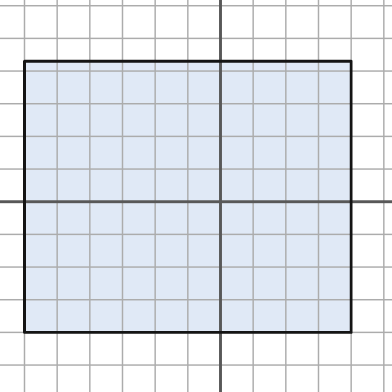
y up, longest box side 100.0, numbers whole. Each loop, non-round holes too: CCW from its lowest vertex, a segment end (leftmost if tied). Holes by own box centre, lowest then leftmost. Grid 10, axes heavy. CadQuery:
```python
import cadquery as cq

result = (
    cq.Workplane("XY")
    .moveTo(-60.0, -40.0)
    .lineTo(40.0, -40.0)
    .lineTo(40.0, 43.0)
    .lineTo(-60.0, 43.0)
    .close()
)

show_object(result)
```